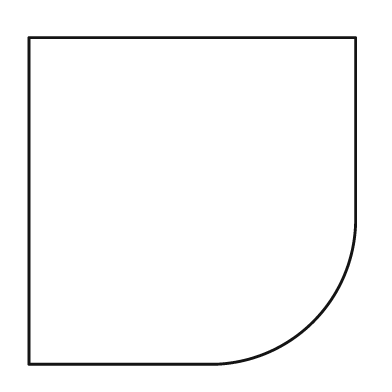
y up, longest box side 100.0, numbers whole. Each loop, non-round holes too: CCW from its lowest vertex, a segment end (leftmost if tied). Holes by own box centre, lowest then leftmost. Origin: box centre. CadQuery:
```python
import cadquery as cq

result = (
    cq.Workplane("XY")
    .moveTo(-50.0, -50.0)
    .lineTo(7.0, -50.0)
    .threePointArc((37.0, -37.0), (50.0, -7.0))
    .lineTo(50.0, 50.0)
    .lineTo(-50.0, 50.0)
    .close()
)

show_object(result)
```